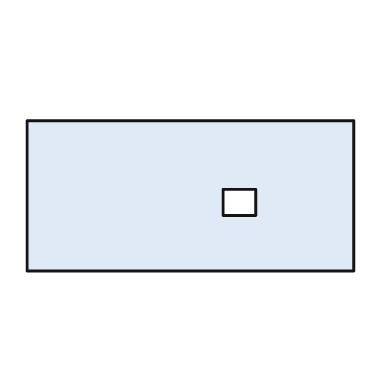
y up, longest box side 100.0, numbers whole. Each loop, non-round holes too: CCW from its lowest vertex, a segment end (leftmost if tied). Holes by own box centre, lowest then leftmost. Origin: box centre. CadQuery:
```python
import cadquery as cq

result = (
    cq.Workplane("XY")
    .moveTo(-50.0, -23.0)
    .lineTo(50.0, -23.0)
    .lineTo(50.0, 23.0)
    .lineTo(-50.0, 23.0)
    .close()
    .moveTo(10.0, -6.0)
    .lineTo(20.0, -6.0)
    .lineTo(20.0, 2.0)
    .lineTo(10.0, 2.0)
    .close()
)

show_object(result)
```